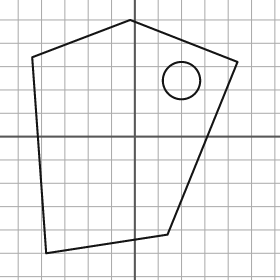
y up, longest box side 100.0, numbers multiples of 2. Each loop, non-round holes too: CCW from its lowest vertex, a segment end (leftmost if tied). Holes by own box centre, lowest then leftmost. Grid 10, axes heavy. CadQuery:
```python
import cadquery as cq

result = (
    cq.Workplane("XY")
    .moveTo(-38.0, -50.0)
    .lineTo(14.0, -42.0)
    .lineTo(44.0, 32.0)
    .lineTo(-2.0, 50.0)
    .lineTo(-44.0, 34.0)
    .close()
    .moveTo(20.0, 24.0)
    .circle(8.0)
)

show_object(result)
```